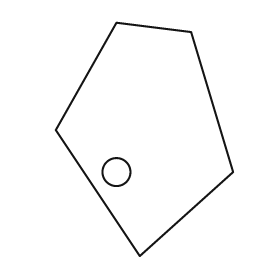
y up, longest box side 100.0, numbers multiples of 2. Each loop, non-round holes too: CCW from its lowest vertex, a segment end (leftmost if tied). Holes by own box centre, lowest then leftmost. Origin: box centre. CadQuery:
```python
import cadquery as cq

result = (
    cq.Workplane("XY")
    .moveTo(-2.0, -50.0)
    .lineTo(38.0, -14.0)
    .lineTo(20.0, 46.0)
    .lineTo(-12.0, 50.0)
    .lineTo(-38.0, 4.0)
    .close()
    .moveTo(-12.0, -14.0)
    .circle(6.0)
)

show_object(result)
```